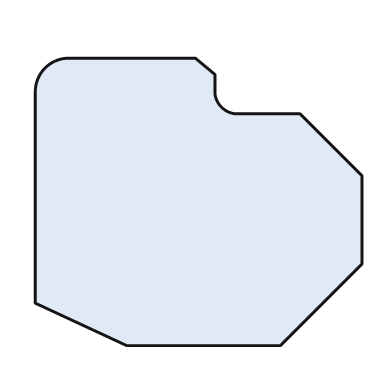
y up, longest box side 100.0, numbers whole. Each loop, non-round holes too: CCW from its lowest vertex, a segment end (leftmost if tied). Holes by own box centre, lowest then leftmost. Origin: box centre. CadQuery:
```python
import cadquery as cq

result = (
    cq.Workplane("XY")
    .moveTo(-22.0, -44.0)
    .lineTo(25.0, -44.0)
    .lineTo(50.0, -19.0)
    .lineTo(50.0, 8.0)
    .lineTo(31.0, 27.0)
    .lineTo(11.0, 27.0)
    .threePointArc((7.0, 29.0), (5.0, 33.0))
    .lineTo(5.0, 39.0)
    .lineTo(-1.0, 44.0)
    .lineTo(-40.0, 44.0)
    .threePointArc((-47.0, 41.0), (-50.0, 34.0))
    .lineTo(-50.0, -31.0)
    .close()
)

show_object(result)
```